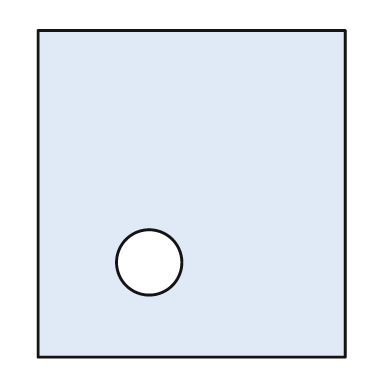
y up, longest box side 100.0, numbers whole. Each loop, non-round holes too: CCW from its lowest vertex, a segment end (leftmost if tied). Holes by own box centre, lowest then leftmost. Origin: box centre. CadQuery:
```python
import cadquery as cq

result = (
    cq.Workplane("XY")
    .moveTo(-47.0, -50.0)
    .lineTo(47.0, -50.0)
    .lineTo(47.0, 50.0)
    .lineTo(-47.0, 50.0)
    .close()
    .moveTo(-13.0, -21.0)
    .circle(10.0)
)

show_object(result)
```